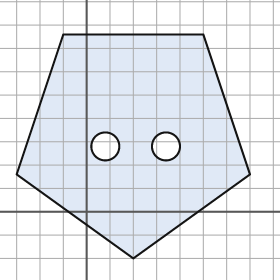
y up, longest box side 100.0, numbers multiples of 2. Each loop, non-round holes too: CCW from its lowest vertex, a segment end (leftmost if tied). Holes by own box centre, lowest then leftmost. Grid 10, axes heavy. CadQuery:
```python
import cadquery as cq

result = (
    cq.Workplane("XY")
    .moveTo(20.0, -20.0)
    .lineTo(70.0, 16.0)
    .lineTo(50.0, 76.0)
    .lineTo(-10.0, 76.0)
    .lineTo(-30.0, 16.0)
    .close()
    .moveTo(8.0, 28.0)
    .circle(6.0)
    .moveTo(34.0, 28.0)
    .circle(6.0)
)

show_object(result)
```